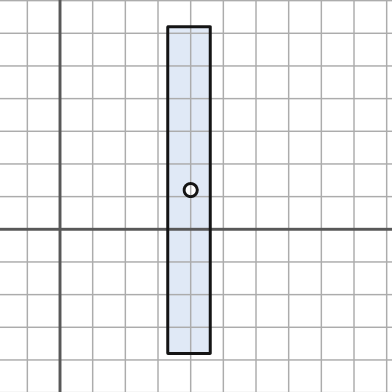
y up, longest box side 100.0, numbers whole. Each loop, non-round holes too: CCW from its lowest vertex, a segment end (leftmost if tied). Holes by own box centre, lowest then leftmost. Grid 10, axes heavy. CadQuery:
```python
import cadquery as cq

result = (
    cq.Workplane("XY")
    .moveTo(33.0, -38.0)
    .lineTo(46.0, -38.0)
    .lineTo(46.0, 62.0)
    .lineTo(33.0, 62.0)
    .close()
    .moveTo(40.0, 12.0)
    .circle(2.0)
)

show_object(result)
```